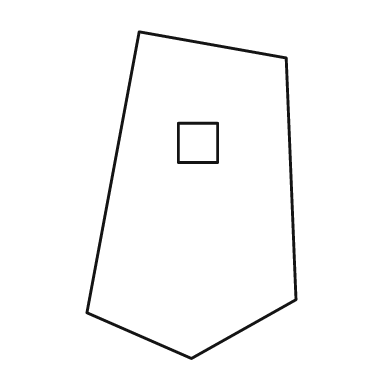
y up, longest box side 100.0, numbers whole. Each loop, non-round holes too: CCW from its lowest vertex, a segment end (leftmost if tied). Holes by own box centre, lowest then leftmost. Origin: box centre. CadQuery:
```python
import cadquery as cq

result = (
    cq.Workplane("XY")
    .moveTo(0.0, -50.0)
    .lineTo(32.0, -32.0)
    .lineTo(29.0, 42.0)
    .lineTo(-16.0, 50.0)
    .lineTo(-32.0, -36.0)
    .close()
    .moveTo(-4.0, 10.0)
    .lineTo(8.0, 10.0)
    .lineTo(8.0, 22.0)
    .lineTo(-4.0, 22.0)
    .close()
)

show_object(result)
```